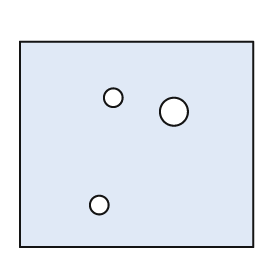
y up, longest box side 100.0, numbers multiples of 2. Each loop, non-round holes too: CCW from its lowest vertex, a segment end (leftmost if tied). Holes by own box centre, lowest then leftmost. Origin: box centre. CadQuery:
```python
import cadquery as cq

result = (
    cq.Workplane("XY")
    .moveTo(-50.0, -44.0)
    .lineTo(50.0, -44.0)
    .lineTo(50.0, 44.0)
    .lineTo(-50.0, 44.0)
    .close()
    .moveTo(-16.0, -26.0)
    .circle(4.0)
    .moveTo(16.0, 14.0)
    .circle(6.0)
    .moveTo(-10.0, 20.0)
    .circle(4.0)
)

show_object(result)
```